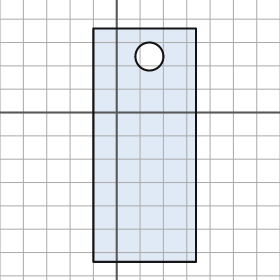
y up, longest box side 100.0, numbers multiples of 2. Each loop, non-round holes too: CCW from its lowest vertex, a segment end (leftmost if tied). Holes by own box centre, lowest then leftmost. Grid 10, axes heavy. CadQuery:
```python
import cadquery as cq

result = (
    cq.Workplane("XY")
    .moveTo(-10.0, -64.0)
    .lineTo(34.0, -64.0)
    .lineTo(34.0, 36.0)
    .lineTo(-10.0, 36.0)
    .close()
    .moveTo(14.0, 24.0)
    .circle(6.0)
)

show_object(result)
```